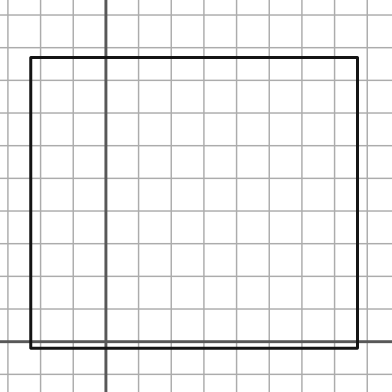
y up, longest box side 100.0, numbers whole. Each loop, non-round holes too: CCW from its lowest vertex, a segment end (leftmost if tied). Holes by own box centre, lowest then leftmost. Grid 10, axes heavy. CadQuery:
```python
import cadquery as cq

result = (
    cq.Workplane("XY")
    .moveTo(-23.0, -2.0)
    .lineTo(77.0, -2.0)
    .lineTo(77.0, 87.0)
    .lineTo(-23.0, 87.0)
    .close()
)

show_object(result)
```